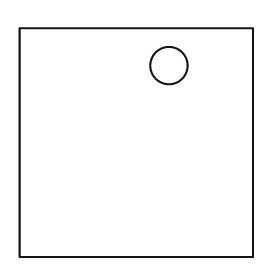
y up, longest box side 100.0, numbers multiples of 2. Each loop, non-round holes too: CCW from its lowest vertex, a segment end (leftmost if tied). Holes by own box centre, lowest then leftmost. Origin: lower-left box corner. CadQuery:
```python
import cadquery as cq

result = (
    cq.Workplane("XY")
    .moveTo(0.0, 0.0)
    .lineTo(100.0, 0.0)
    .lineTo(100.0, 98.0)
    .lineTo(0.0, 98.0)
    .close()
    .moveTo(64.0, 82.0)
    .circle(8.0)
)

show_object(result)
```